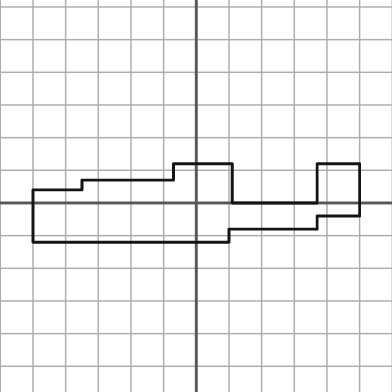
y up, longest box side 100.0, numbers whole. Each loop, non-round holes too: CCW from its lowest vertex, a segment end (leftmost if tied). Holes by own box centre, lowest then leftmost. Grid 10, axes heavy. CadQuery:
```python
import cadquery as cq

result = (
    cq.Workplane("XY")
    .moveTo(-50.0, -12.0)
    .lineTo(10.0, -12.0)
    .lineTo(10.0, -8.0)
    .lineTo(37.0, -8.0)
    .lineTo(37.0, -4.0)
    .lineTo(50.0, -4.0)
    .lineTo(50.0, 12.0)
    .lineTo(37.0, 12.0)
    .lineTo(37.0, 0.0)
    .lineTo(11.0, 0.0)
    .lineTo(11.0, 12.0)
    .lineTo(-7.0, 12.0)
    .lineTo(-7.0, 7.0)
    .lineTo(-35.0, 7.0)
    .lineTo(-35.0, 4.0)
    .lineTo(-50.0, 4.0)
    .close()
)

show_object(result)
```